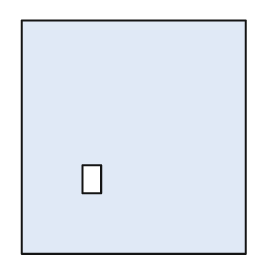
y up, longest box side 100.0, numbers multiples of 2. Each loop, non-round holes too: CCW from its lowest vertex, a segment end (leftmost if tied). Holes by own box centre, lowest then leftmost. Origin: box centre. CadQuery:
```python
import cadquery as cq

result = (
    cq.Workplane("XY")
    .moveTo(-48.0, -50.0)
    .lineTo(48.0, -50.0)
    .lineTo(48.0, 50.0)
    .lineTo(-48.0, 50.0)
    .close()
    .moveTo(-22.0, -24.0)
    .lineTo(-14.0, -24.0)
    .lineTo(-14.0, -12.0)
    .lineTo(-22.0, -12.0)
    .close()
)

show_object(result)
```